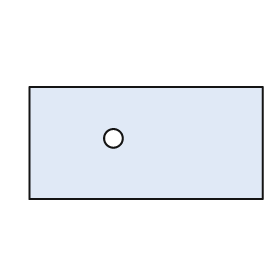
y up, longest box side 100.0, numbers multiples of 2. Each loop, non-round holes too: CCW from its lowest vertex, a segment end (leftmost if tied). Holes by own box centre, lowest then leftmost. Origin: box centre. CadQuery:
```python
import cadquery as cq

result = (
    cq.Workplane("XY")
    .moveTo(-50.0, -24.0)
    .lineTo(50.0, -24.0)
    .lineTo(50.0, 24.0)
    .lineTo(-50.0, 24.0)
    .close()
    .moveTo(-14.0, 2.0)
    .circle(4.0)
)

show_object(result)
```